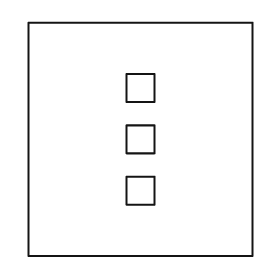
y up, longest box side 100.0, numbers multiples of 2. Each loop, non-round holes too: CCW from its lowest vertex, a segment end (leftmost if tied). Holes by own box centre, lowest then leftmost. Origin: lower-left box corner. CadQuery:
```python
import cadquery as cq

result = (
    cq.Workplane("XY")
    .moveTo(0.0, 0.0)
    .lineTo(96.0, 0.0)
    .lineTo(96.0, 100.0)
    .lineTo(0.0, 100.0)
    .close()
    .moveTo(42.0, 22.0)
    .lineTo(54.0, 22.0)
    .lineTo(54.0, 34.0)
    .lineTo(42.0, 34.0)
    .close()
    .moveTo(42.0, 44.0)
    .lineTo(54.0, 44.0)
    .lineTo(54.0, 56.0)
    .lineTo(42.0, 56.0)
    .close()
    .moveTo(42.0, 66.0)
    .lineTo(54.0, 66.0)
    .lineTo(54.0, 78.0)
    .lineTo(42.0, 78.0)
    .close()
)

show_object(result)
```